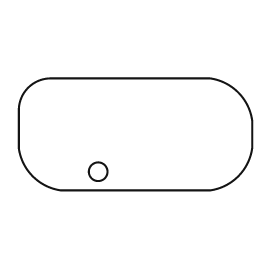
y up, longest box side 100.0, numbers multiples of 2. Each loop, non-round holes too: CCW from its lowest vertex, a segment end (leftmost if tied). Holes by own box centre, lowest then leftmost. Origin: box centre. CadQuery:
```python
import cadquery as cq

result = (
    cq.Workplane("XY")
    .moveTo(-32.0, -24.0)
    .lineTo(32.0, -24.0)
    .threePointArc((44.0, -18.0), (50.0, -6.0))
    .lineTo(50.0, 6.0)
    .threePointArc((44.0, 18.0), (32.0, 24.0))
    .lineTo(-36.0, 24.0)
    .threePointArc((-46.0, 20.0), (-50.0, 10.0))
    .lineTo(-50.0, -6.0)
    .threePointArc((-44.0, -18.0), (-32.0, -24.0))
    .close()
    .moveTo(-16.0, -16.0)
    .circle(4.0)
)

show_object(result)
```